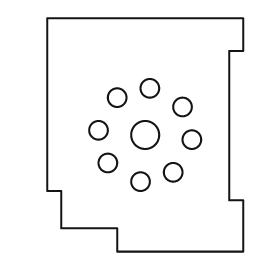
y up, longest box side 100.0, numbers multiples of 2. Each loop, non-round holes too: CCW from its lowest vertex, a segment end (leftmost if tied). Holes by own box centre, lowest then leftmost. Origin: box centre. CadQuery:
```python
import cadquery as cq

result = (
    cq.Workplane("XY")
    .moveTo(-12.0, -50.0)
    .lineTo(42.0, -50.0)
    .lineTo(42.0, -28.0)
    .lineTo(36.0, -28.0)
    .lineTo(36.0, 36.0)
    .lineTo(42.0, 36.0)
    .lineTo(42.0, 50.0)
    .lineTo(-42.0, 50.0)
    .lineTo(-42.0, -24.0)
    .lineTo(-36.0, -24.0)
    .lineTo(-36.0, -40.0)
    .lineTo(-12.0, -40.0)
    .close()
    .moveTo(-2.0, -20.0)
    .circle(4.0)
    .moveTo(12.0, -16.0)
    .circle(4.0)
    .moveTo(-16.0, -12.0)
    .circle(4.0)
    .moveTo(20.0, -2.0)
    .circle(4.0)
    .moveTo(0.0, 0.0)
    .circle(6.0)
    .moveTo(-20.0, 2.0)
    .circle(4.0)
    .moveTo(16.0, 12.0)
    .circle(4.0)
    .moveTo(-12.0, 16.0)
    .circle(4.0)
    .moveTo(2.0, 20.0)
    .circle(4.0)
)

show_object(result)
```